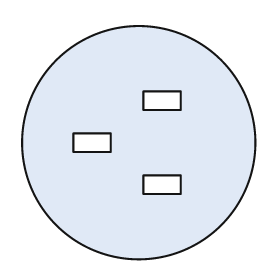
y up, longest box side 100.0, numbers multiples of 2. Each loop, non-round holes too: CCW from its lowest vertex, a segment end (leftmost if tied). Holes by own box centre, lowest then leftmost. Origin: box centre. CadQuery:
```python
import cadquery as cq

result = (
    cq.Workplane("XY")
    .moveTo(0.0, 0.0)
    .circle(50.0)
    .moveTo(2.0, -22.0)
    .lineTo(18.0, -22.0)
    .lineTo(18.0, -14.0)
    .lineTo(2.0, -14.0)
    .close()
    .moveTo(-28.0, -4.0)
    .lineTo(-12.0, -4.0)
    .lineTo(-12.0, 4.0)
    .lineTo(-28.0, 4.0)
    .close()
    .moveTo(2.0, 14.0)
    .lineTo(18.0, 14.0)
    .lineTo(18.0, 22.0)
    .lineTo(2.0, 22.0)
    .close()
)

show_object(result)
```